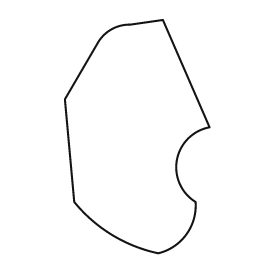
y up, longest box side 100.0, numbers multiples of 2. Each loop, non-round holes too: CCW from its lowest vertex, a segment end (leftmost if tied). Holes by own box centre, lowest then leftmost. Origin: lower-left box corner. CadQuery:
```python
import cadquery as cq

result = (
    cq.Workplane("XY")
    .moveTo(40.0, 0.0)
    .threePointArc((52.0, 8.0), (56.0, 22.0))
    .threePointArc((48.0, 40.0), (62.0, 54.0))
    .lineTo(42.0, 100.0)
    .lineTo(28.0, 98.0)
    .threePointArc((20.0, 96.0), (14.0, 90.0))
    .lineTo(0.0, 66.0)
    .lineTo(4.0, 22.0)
    .threePointArc((20.0, 8.0), (40.0, 0.0))
    .close()
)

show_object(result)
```